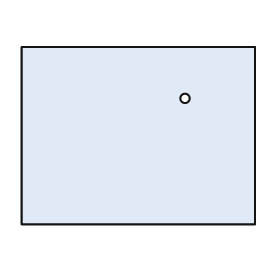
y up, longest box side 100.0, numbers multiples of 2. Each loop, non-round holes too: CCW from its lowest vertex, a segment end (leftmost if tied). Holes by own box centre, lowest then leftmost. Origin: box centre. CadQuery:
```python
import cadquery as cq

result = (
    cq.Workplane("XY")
    .moveTo(-50.0, -38.0)
    .lineTo(50.0, -38.0)
    .lineTo(50.0, 38.0)
    .lineTo(-50.0, 38.0)
    .close()
    .moveTo(20.0, 16.0)
    .circle(2.0)
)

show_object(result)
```